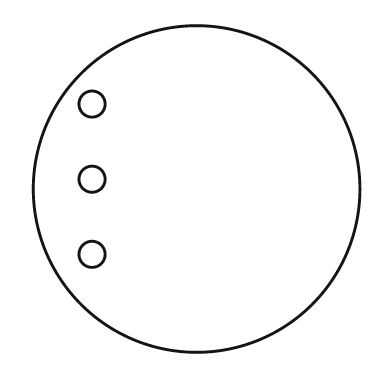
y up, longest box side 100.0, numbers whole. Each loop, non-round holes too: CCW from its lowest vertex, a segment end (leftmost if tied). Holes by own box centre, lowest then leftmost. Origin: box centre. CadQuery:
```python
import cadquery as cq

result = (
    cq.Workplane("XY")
    .moveTo(0.0, 0.0)
    .circle(50.0)
    .moveTo(-32.0, -20.0)
    .circle(4.0)
    .moveTo(-32.0, 3.0)
    .circle(4.0)
    .moveTo(-32.0, 26.0)
    .circle(4.0)
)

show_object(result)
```